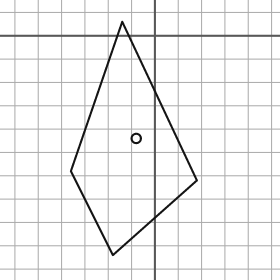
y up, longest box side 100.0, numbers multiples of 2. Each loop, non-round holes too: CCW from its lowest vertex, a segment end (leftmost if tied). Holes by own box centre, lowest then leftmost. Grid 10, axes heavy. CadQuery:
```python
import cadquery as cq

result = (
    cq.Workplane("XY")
    .moveTo(-18.0, -94.0)
    .lineTo(18.0, -62.0)
    .lineTo(-14.0, 6.0)
    .lineTo(-36.0, -58.0)
    .close()
    .moveTo(-8.0, -44.0)
    .circle(2.0)
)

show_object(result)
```